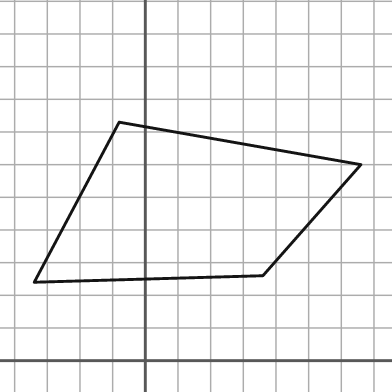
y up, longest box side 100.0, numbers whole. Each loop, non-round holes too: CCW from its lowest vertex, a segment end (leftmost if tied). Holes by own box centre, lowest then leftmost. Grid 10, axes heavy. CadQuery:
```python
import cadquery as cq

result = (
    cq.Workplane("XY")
    .moveTo(-34.0, 24.0)
    .lineTo(36.0, 26.0)
    .lineTo(66.0, 60.0)
    .lineTo(-8.0, 73.0)
    .close()
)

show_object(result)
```